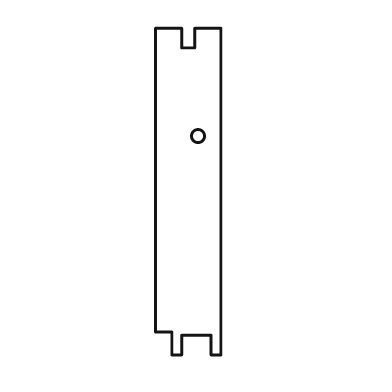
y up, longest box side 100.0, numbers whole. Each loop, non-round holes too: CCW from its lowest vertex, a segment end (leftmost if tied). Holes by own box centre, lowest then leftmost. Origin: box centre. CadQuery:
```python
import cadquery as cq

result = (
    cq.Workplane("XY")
    .moveTo(-5.0, -50.0)
    .lineTo(-2.0, -50.0)
    .lineTo(-2.0, -44.0)
    .lineTo(7.0, -44.0)
    .lineTo(7.0, -50.0)
    .lineTo(10.0, -50.0)
    .lineTo(10.0, 50.0)
    .lineTo(2.0, 50.0)
    .lineTo(2.0, 44.0)
    .lineTo(-2.0, 44.0)
    .lineTo(-2.0, 50.0)
    .lineTo(-10.0, 50.0)
    .lineTo(-10.0, -43.0)
    .lineTo(-5.0, -43.0)
    .close()
    .moveTo(3.0, 17.0)
    .circle(2.0)
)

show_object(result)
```